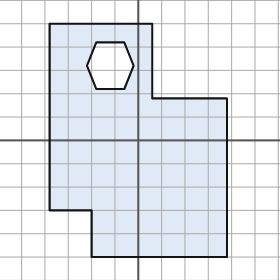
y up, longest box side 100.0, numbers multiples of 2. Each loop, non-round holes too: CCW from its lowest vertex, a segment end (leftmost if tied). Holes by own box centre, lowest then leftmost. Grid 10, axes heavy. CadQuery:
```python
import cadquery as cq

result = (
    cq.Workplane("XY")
    .moveTo(-20.0, -50.0)
    .lineTo(38.0, -50.0)
    .lineTo(38.0, 18.0)
    .lineTo(6.0, 18.0)
    .lineTo(6.0, 50.0)
    .lineTo(-38.0, 50.0)
    .lineTo(-38.0, -30.0)
    .lineTo(-20.0, -30.0)
    .close()
    .moveTo(-18.0, 22.0)
    .lineTo(-6.0, 22.0)
    .lineTo(-2.0, 32.0)
    .lineTo(-6.0, 42.0)
    .lineTo(-18.0, 42.0)
    .lineTo(-22.0, 32.0)
    .close()
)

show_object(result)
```